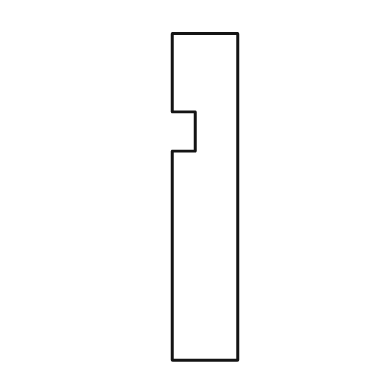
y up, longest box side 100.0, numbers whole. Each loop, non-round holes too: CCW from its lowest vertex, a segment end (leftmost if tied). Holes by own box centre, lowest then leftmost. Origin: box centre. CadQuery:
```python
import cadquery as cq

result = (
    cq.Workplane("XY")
    .moveTo(-10.0, -50.0)
    .lineTo(10.0, -50.0)
    .lineTo(10.0, 50.0)
    .lineTo(-10.0, 50.0)
    .lineTo(-10.0, 26.0)
    .lineTo(-3.0, 26.0)
    .lineTo(-3.0, 14.0)
    .lineTo(-10.0, 14.0)
    .close()
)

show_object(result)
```